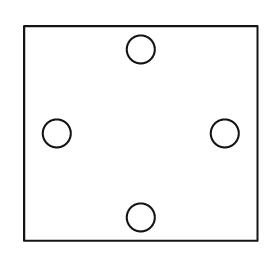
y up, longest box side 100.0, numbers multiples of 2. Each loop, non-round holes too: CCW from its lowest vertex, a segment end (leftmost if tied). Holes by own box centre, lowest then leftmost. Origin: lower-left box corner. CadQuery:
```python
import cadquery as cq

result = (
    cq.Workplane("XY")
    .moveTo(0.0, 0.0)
    .lineTo(100.0, 0.0)
    .lineTo(100.0, 92.0)
    .lineTo(0.0, 92.0)
    .close()
    .moveTo(50.0, 10.0)
    .circle(6.0)
    .moveTo(14.0, 46.0)
    .circle(6.0)
    .moveTo(86.0, 46.0)
    .circle(6.0)
    .moveTo(50.0, 82.0)
    .circle(6.0)
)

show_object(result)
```